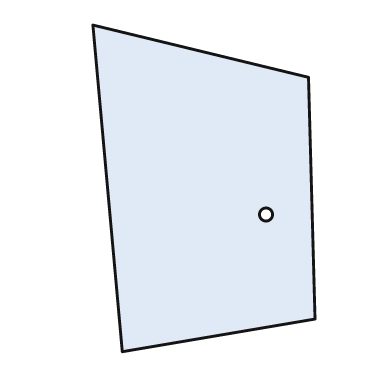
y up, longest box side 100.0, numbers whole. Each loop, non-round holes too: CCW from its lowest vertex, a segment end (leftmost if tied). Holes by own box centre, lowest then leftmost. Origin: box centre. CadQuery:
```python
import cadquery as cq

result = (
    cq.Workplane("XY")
    .moveTo(-25.0, -50.0)
    .lineTo(34.0, -40.0)
    .lineTo(32.0, 34.0)
    .lineTo(-34.0, 50.0)
    .close()
    .moveTo(19.0, -8.0)
    .circle(2.0)
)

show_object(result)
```